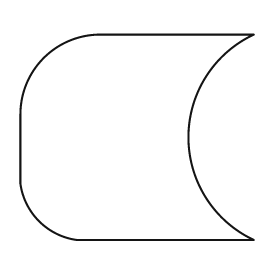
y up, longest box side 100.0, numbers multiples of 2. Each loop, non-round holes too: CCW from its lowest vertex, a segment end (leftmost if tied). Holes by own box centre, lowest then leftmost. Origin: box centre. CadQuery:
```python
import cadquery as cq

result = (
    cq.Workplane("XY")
    .moveTo(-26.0, -44.0)
    .lineTo(50.0, -44.0)
    .threePointArc((22.0, 0.0), (50.0, 44.0))
    .lineTo(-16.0, 44.0)
    .threePointArc((-40.0, 34.0), (-50.0, 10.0))
    .lineTo(-50.0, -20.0)
    .threePointArc((-42.0, -36.0), (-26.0, -44.0))
    .close()
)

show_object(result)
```